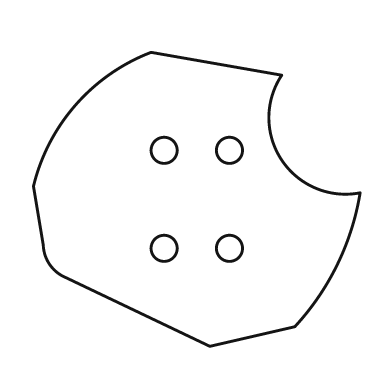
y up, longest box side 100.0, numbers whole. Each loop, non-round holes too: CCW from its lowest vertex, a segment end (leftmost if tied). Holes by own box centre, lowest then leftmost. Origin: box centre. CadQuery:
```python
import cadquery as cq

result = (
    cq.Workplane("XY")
    .moveTo(4.0, -45.0)
    .lineTo(30.0, -39.0)
    .threePointArc((43.0, -20.0), (50.0, 2.0))
    .threePointArc((26.0, 12.0), (26.0, 38.0))
    .lineTo(-14.0, 45.0)
    .threePointArc((-37.0, 29.0), (-50.0, 4.0))
    .lineTo(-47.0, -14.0)
    .threePointArc((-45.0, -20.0), (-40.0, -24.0))
    .close()
    .moveTo(-10.0, -15.0)
    .circle(4.0)
    .moveTo(10.0, -15.0)
    .circle(4.0)
    .moveTo(-10.0, 15.0)
    .circle(4.0)
    .moveTo(10.0, 15.0)
    .circle(4.0)
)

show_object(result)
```